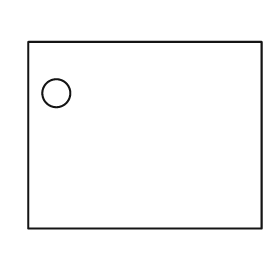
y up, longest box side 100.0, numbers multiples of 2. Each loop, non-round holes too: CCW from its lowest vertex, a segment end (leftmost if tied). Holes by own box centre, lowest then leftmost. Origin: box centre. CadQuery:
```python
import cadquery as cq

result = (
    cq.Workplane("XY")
    .moveTo(-50.0, -40.0)
    .lineTo(50.0, -40.0)
    .lineTo(50.0, 40.0)
    .lineTo(-50.0, 40.0)
    .close()
    .moveTo(-38.0, 18.0)
    .circle(6.0)
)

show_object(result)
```